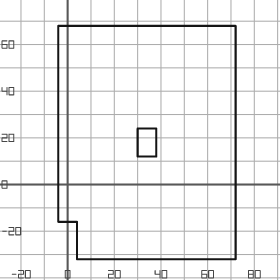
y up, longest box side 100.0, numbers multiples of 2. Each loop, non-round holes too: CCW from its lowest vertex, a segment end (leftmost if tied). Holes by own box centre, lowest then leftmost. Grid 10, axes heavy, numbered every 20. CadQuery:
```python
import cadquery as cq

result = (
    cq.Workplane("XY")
    .moveTo(4.0, -32.0)
    .lineTo(72.0, -32.0)
    .lineTo(72.0, 68.0)
    .lineTo(-4.0, 68.0)
    .lineTo(-4.0, -16.0)
    .lineTo(4.0, -16.0)
    .close()
    .moveTo(30.0, 12.0)
    .lineTo(38.0, 12.0)
    .lineTo(38.0, 24.0)
    .lineTo(30.0, 24.0)
    .close()
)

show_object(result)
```